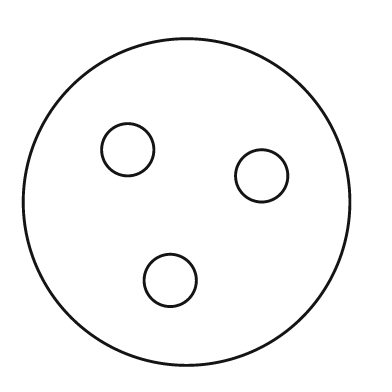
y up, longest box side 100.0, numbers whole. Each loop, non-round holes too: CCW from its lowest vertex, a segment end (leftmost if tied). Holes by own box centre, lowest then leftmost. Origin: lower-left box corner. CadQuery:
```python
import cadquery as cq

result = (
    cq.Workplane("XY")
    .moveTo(50.0, 50.0)
    .circle(50.0)
    .moveTo(45.0, 26.0)
    .circle(8.0)
    .moveTo(73.0, 58.0)
    .circle(8.0)
    .moveTo(32.0, 66.0)
    .circle(8.0)
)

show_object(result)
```